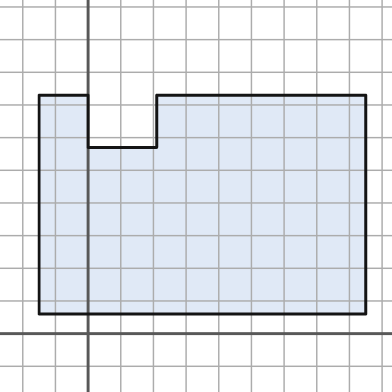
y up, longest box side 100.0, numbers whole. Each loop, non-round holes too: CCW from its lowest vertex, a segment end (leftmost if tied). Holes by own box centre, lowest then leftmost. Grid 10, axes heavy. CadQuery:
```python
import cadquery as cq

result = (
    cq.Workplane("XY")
    .moveTo(-15.0, 6.0)
    .lineTo(85.0, 6.0)
    .lineTo(85.0, 73.0)
    .lineTo(21.0, 73.0)
    .lineTo(21.0, 57.0)
    .lineTo(0.0, 57.0)
    .lineTo(0.0, 73.0)
    .lineTo(-15.0, 73.0)
    .close()
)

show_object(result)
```